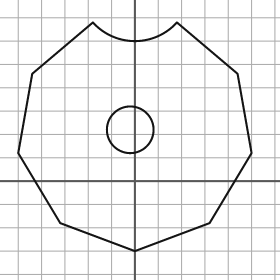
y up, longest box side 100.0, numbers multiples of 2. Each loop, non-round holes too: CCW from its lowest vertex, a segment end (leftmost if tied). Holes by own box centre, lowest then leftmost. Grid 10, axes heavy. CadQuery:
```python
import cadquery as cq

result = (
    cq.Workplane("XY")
    .moveTo(0.0, -30.0)
    .lineTo(32.0, -18.0)
    .lineTo(50.0, 12.0)
    .lineTo(44.0, 46.0)
    .lineTo(18.0, 68.0)
    .threePointArc((0.0, 60.0), (-18.0, 68.0))
    .lineTo(-44.0, 46.0)
    .lineTo(-50.0, 12.0)
    .lineTo(-32.0, -18.0)
    .close()
    .moveTo(-2.0, 22.0)
    .circle(10.0)
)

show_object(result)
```